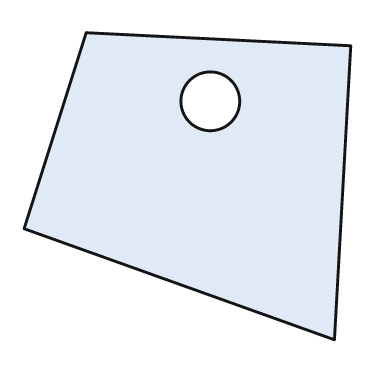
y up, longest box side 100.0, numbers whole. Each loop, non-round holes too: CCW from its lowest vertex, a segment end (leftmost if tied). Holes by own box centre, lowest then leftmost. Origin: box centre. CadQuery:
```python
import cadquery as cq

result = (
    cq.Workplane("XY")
    .moveTo(45.0, -47.0)
    .lineTo(50.0, 43.0)
    .lineTo(-31.0, 47.0)
    .lineTo(-50.0, -13.0)
    .close()
    .moveTo(7.0, 26.0)
    .circle(9.0)
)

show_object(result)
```